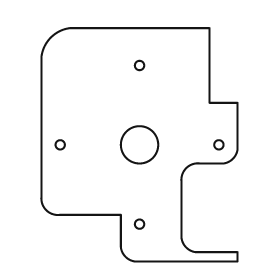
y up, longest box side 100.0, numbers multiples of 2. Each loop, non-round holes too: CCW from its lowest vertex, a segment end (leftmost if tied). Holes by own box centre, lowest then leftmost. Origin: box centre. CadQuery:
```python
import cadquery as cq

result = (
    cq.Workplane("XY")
    .moveTo(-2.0, -50.0)
    .lineTo(42.0, -50.0)
    .lineTo(42.0, -46.0)
    .lineTo(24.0, -46.0)
    .threePointArc((20.0, -44.0), (18.0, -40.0))
    .lineTo(18.0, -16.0)
    .threePointArc((20.0, -10.0), (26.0, -8.0))
    .lineTo(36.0, -8.0)
    .threePointArc((40.0, -6.0), (42.0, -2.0))
    .lineTo(42.0, 18.0)
    .lineTo(30.0, 18.0)
    .lineTo(30.0, 50.0)
    .lineTo(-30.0, 50.0)
    .threePointArc((-38.0, 46.0), (-42.0, 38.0))
    .lineTo(-42.0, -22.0)
    .threePointArc((-40.0, -28.0), (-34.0, -30.0))
    .lineTo(-8.0, -30.0)
    .lineTo(-8.0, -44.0)
    .threePointArc((-6.0, -48.0), (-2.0, -50.0))
    .close()
    .moveTo(0.0, -34.0)
    .circle(2.0)
    .moveTo(-34.0, 0.0)
    .circle(2.0)
    .moveTo(0.0, 0.0)
    .circle(8.0)
    .moveTo(34.0, 0.0)
    .circle(2.0)
    .moveTo(0.0, 34.0)
    .circle(2.0)
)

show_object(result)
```